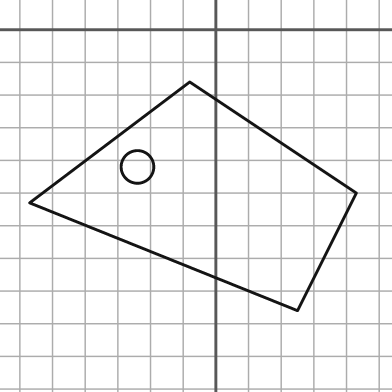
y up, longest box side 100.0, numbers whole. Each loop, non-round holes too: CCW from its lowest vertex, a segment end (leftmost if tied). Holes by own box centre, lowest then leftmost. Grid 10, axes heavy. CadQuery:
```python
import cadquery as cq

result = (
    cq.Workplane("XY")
    .moveTo(25.0, -86.0)
    .lineTo(43.0, -50.0)
    .lineTo(-8.0, -16.0)
    .lineTo(-57.0, -53.0)
    .close()
    .moveTo(-24.0, -42.0)
    .circle(5.0)
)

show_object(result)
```